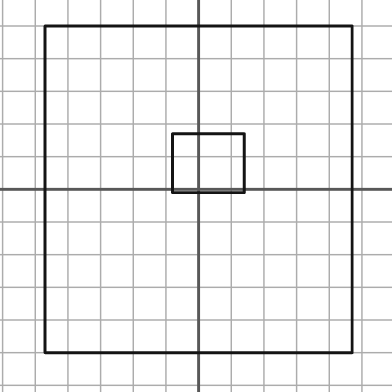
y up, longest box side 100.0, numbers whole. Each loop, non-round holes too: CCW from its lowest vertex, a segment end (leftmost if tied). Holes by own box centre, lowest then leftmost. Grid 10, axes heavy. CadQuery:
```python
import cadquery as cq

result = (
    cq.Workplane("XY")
    .moveTo(-47.0, -50.0)
    .lineTo(47.0, -50.0)
    .lineTo(47.0, 50.0)
    .lineTo(-47.0, 50.0)
    .close()
    .moveTo(-8.0, -1.0)
    .lineTo(14.0, -1.0)
    .lineTo(14.0, 17.0)
    .lineTo(-8.0, 17.0)
    .close()
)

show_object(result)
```